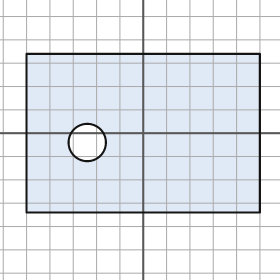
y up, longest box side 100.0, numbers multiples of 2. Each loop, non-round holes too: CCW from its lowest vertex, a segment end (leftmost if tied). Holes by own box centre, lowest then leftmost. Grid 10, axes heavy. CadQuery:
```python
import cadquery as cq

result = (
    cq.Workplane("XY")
    .moveTo(-50.0, -34.0)
    .lineTo(50.0, -34.0)
    .lineTo(50.0, 34.0)
    .lineTo(-50.0, 34.0)
    .close()
    .moveTo(-24.0, -4.0)
    .circle(8.0)
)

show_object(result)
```